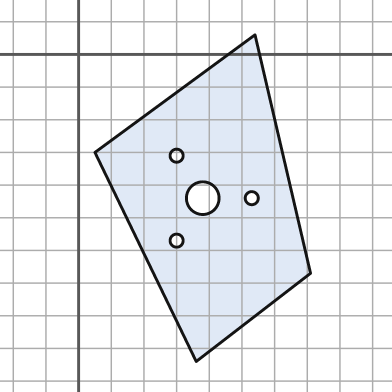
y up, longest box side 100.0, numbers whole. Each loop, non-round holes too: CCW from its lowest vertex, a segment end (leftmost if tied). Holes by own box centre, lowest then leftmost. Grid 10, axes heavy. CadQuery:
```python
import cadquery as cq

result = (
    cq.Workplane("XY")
    .moveTo(36.0, -94.0)
    .lineTo(71.0, -67.0)
    .lineTo(54.0, 6.0)
    .lineTo(5.0, -30.0)
    .close()
    .moveTo(30.0, -57.0)
    .circle(2.0)
    .moveTo(38.0, -44.0)
    .circle(5.0)
    .moveTo(53.0, -44.0)
    .circle(2.0)
    .moveTo(30.0, -31.0)
    .circle(2.0)
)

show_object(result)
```